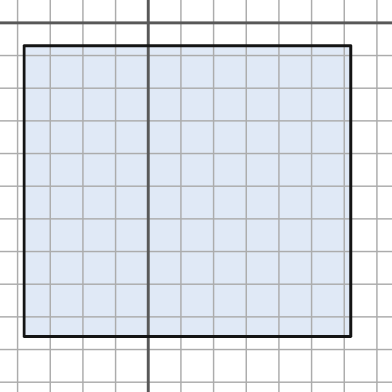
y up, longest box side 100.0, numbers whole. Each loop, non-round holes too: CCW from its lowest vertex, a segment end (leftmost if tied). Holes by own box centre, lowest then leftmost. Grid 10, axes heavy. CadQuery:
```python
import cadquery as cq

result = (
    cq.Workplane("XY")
    .moveTo(-38.0, -96.0)
    .lineTo(62.0, -96.0)
    .lineTo(62.0, -7.0)
    .lineTo(-38.0, -7.0)
    .close()
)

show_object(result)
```